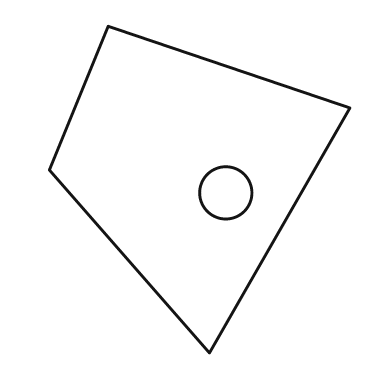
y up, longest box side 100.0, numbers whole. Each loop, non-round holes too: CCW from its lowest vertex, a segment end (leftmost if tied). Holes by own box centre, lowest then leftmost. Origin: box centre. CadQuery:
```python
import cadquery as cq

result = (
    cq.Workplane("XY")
    .moveTo(3.0, -50.0)
    .lineTo(46.0, 25.0)
    .lineTo(-28.0, 50.0)
    .lineTo(-46.0, 6.0)
    .close()
    .moveTo(8.0, -1.0)
    .circle(8.0)
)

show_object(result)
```